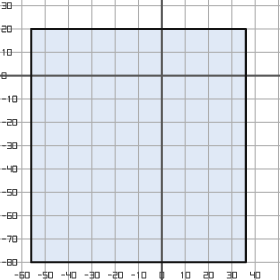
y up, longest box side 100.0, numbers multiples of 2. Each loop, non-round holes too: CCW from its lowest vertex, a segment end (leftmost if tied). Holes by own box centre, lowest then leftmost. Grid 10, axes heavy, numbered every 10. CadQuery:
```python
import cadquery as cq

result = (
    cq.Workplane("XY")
    .moveTo(-56.0, -80.0)
    .lineTo(36.0, -80.0)
    .lineTo(36.0, 20.0)
    .lineTo(-56.0, 20.0)
    .close()
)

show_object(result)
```